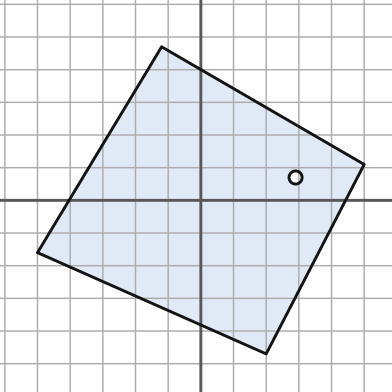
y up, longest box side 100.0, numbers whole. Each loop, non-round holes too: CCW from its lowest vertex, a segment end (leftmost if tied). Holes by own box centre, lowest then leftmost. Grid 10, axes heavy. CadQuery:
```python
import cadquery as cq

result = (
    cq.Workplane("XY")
    .moveTo(20.0, -47.0)
    .lineTo(50.0, 11.0)
    .lineTo(-12.0, 47.0)
    .lineTo(-50.0, -16.0)
    .close()
    .moveTo(29.0, 7.0)
    .circle(2.0)
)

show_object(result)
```